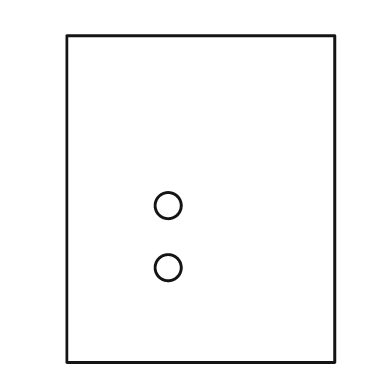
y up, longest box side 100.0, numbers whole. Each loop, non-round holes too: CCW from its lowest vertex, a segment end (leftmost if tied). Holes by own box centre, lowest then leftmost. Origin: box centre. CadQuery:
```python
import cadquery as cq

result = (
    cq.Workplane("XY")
    .moveTo(-41.0, -50.0)
    .lineTo(41.0, -50.0)
    .lineTo(41.0, 50.0)
    .lineTo(-41.0, 50.0)
    .close()
    .moveTo(-10.0, -21.0)
    .circle(4.0)
    .moveTo(-10.0, -2.0)
    .circle(4.0)
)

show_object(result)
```